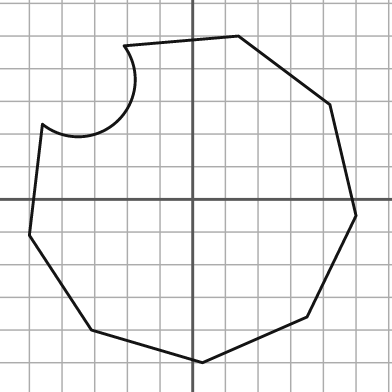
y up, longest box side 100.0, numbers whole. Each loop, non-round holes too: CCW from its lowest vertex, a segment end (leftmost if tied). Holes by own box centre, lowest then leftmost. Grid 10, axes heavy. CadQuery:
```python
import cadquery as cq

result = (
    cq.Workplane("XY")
    .moveTo(3.0, -50.0)
    .lineTo(35.0, -36.0)
    .lineTo(50.0, -5.0)
    .lineTo(42.0, 29.0)
    .lineTo(14.0, 50.0)
    .lineTo(-21.0, 47.0)
    .threePointArc((-23.0, 24.0), (-46.0, 23.0))
    .lineTo(-50.0, -11.0)
    .lineTo(-31.0, -40.0)
    .close()
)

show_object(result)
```